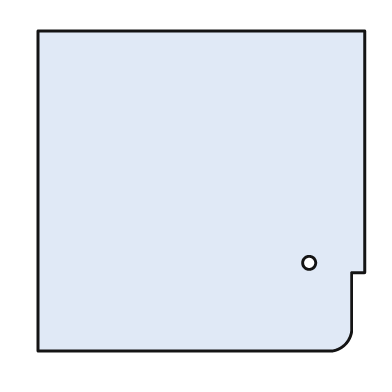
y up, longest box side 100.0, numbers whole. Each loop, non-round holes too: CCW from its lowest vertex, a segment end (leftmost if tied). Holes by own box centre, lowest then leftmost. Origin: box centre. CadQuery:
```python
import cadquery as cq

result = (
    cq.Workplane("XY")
    .moveTo(-50.0, -49.0)
    .lineTo(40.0, -49.0)
    .threePointArc((44.0, -47.0), (46.0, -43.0))
    .lineTo(46.0, -25.0)
    .lineTo(50.0, -25.0)
    .lineTo(50.0, 49.0)
    .lineTo(-50.0, 49.0)
    .close()
    .moveTo(33.0, -22.0)
    .circle(2.0)
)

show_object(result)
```